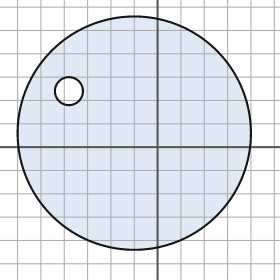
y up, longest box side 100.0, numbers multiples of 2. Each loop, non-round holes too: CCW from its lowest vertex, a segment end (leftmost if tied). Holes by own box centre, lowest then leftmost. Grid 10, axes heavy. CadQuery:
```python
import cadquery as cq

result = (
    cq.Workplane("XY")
    .moveTo(-10.0, 6.0)
    .circle(50.0)
    .moveTo(-38.0, 24.0)
    .circle(6.0)
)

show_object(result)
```